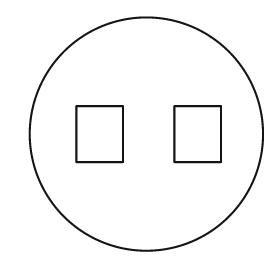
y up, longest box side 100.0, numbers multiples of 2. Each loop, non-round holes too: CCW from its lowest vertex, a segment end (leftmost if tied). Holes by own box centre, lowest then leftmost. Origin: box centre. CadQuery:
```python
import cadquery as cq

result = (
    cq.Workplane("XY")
    .moveTo(0.0, 0.0)
    .circle(50.0)
    .moveTo(-30.0, -12.0)
    .lineTo(-10.0, -12.0)
    .lineTo(-10.0, 12.0)
    .lineTo(-30.0, 12.0)
    .close()
    .moveTo(12.0, -12.0)
    .lineTo(32.0, -12.0)
    .lineTo(32.0, 12.0)
    .lineTo(12.0, 12.0)
    .close()
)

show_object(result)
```